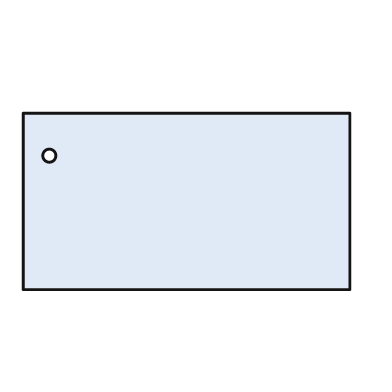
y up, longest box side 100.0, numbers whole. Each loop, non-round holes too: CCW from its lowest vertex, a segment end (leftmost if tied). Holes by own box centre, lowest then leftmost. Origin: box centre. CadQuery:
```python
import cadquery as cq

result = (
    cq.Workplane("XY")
    .moveTo(-50.0, -27.0)
    .lineTo(50.0, -27.0)
    .lineTo(50.0, 27.0)
    .lineTo(-50.0, 27.0)
    .close()
    .moveTo(-42.0, 14.0)
    .circle(2.0)
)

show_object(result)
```